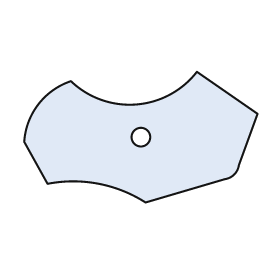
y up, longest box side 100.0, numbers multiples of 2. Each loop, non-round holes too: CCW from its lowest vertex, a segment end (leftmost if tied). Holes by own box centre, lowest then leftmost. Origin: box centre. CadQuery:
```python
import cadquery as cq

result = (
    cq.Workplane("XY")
    .moveTo(2.0, -28.0)
    .lineTo(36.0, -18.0)
    .threePointArc((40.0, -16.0), (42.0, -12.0))
    .lineTo(50.0, 10.0)
    .lineTo(24.0, 28.0)
    .threePointArc((-2.0, 14.0), (-30.0, 24.0))
    .threePointArc((-44.0, 14.0), (-50.0, -2.0))
    .lineTo(-40.0, -20.0)
    .threePointArc((-18.0, -20.0), (2.0, -28.0))
    .close()
    .moveTo(0.0, 0.0)
    .circle(4.0)
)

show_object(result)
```